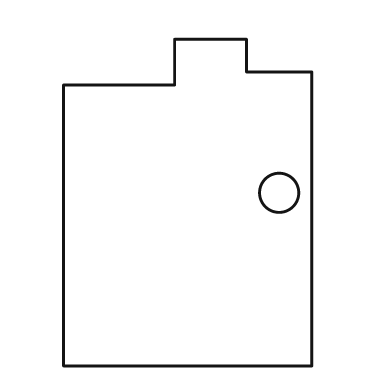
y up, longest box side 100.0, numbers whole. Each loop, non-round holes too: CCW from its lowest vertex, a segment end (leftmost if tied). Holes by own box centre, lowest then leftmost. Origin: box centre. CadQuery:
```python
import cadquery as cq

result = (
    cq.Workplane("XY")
    .moveTo(-38.0, -50.0)
    .lineTo(38.0, -50.0)
    .lineTo(38.0, 40.0)
    .lineTo(18.0, 40.0)
    .lineTo(18.0, 50.0)
    .lineTo(-4.0, 50.0)
    .lineTo(-4.0, 36.0)
    .lineTo(-38.0, 36.0)
    .close()
    .moveTo(28.0, 3.0)
    .circle(6.0)
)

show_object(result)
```